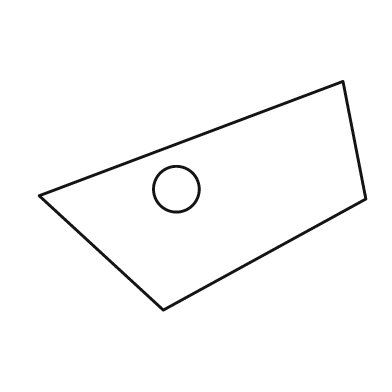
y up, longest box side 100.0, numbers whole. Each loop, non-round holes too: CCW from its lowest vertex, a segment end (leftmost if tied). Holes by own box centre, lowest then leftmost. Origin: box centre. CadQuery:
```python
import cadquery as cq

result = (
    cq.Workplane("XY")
    .moveTo(-12.0, -35.0)
    .lineTo(50.0, -1.0)
    .lineTo(43.0, 35.0)
    .lineTo(-50.0, 0.0)
    .close()
    .moveTo(-8.0, 2.0)
    .circle(7.0)
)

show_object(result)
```